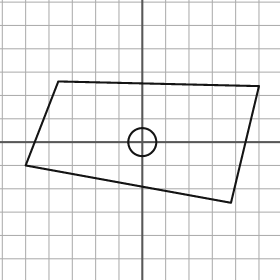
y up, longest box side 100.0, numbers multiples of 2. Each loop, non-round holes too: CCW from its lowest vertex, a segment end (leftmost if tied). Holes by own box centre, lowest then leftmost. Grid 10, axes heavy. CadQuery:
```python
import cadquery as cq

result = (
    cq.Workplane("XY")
    .moveTo(38.0, -26.0)
    .lineTo(50.0, 24.0)
    .lineTo(-36.0, 26.0)
    .lineTo(-50.0, -10.0)
    .close()
    .moveTo(0.0, 0.0)
    .circle(6.0)
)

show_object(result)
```